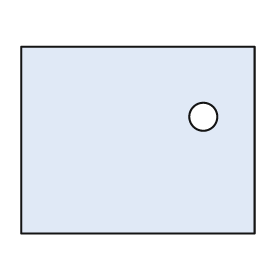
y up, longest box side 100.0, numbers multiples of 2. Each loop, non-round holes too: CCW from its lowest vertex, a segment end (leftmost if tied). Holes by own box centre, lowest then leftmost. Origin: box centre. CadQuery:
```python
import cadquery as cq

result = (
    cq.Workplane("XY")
    .moveTo(-50.0, -40.0)
    .lineTo(50.0, -40.0)
    .lineTo(50.0, 40.0)
    .lineTo(-50.0, 40.0)
    .close()
    .moveTo(28.0, 10.0)
    .circle(6.0)
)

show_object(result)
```